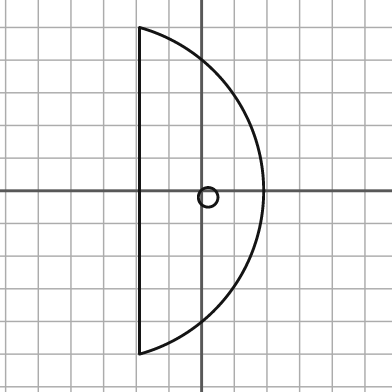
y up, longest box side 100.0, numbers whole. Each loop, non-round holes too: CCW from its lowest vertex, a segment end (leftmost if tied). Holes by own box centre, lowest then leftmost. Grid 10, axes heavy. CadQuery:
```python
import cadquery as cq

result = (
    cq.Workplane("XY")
    .moveTo(-19.0, -50.0)
    .threePointArc((19.0, 0.0), (-19.0, 50.0))
    .close()
    .moveTo(2.0, -2.0)
    .circle(3.0)
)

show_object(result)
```